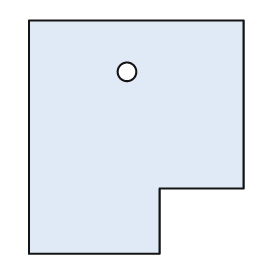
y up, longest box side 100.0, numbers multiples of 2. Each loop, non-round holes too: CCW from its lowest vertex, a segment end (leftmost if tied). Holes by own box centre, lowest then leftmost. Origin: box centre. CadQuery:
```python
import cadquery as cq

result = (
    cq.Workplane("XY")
    .moveTo(-46.0, -50.0)
    .lineTo(10.0, -50.0)
    .lineTo(10.0, -22.0)
    .lineTo(46.0, -22.0)
    .lineTo(46.0, 50.0)
    .lineTo(-46.0, 50.0)
    .close()
    .moveTo(-4.0, 28.0)
    .circle(4.0)
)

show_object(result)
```